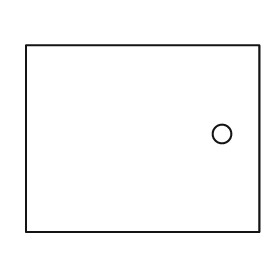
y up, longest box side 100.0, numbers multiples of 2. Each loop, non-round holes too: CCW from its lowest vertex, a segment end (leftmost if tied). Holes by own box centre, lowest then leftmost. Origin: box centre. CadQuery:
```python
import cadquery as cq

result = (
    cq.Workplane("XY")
    .moveTo(-50.0, -40.0)
    .lineTo(50.0, -40.0)
    .lineTo(50.0, 40.0)
    .lineTo(-50.0, 40.0)
    .close()
    .moveTo(34.0, 2.0)
    .circle(4.0)
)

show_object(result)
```